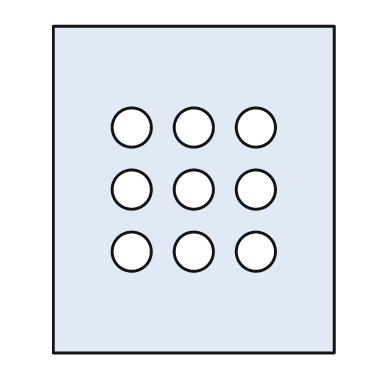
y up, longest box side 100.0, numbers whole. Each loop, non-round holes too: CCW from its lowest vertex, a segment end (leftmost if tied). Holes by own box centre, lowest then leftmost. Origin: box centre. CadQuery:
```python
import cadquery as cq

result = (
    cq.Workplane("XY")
    .moveTo(-43.0, -50.0)
    .lineTo(43.0, -50.0)
    .lineTo(43.0, 50.0)
    .lineTo(-43.0, 50.0)
    .close()
    .moveTo(-19.0, -19.0)
    .circle(6.0)
    .moveTo(0.0, -19.0)
    .circle(6.0)
    .moveTo(19.0, -19.0)
    .circle(6.0)
    .moveTo(-19.0, 0.0)
    .circle(6.0)
    .moveTo(0.0, 0.0)
    .circle(6.0)
    .moveTo(19.0, 0.0)
    .circle(6.0)
    .moveTo(-19.0, 19.0)
    .circle(6.0)
    .moveTo(0.0, 19.0)
    .circle(6.0)
    .moveTo(19.0, 19.0)
    .circle(6.0)
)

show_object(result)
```